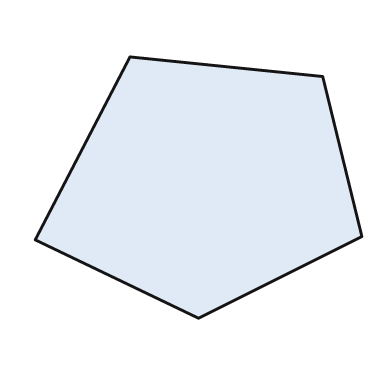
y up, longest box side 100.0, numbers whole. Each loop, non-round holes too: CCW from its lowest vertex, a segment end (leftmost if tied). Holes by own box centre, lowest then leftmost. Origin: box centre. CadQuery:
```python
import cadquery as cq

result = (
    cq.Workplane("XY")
    .moveTo(0.0, -40.0)
    .lineTo(50.0, -15.0)
    .lineTo(38.0, 34.0)
    .lineTo(-21.0, 40.0)
    .lineTo(-50.0, -16.0)
    .close()
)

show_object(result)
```